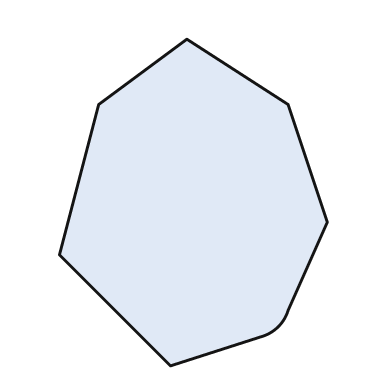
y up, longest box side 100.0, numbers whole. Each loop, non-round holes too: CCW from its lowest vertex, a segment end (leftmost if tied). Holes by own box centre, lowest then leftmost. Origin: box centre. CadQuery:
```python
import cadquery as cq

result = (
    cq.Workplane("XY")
    .moveTo(-7.0, -50.0)
    .lineTo(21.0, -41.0)
    .threePointArc((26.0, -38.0), (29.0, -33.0))
    .lineTo(41.0, -6.0)
    .lineTo(29.0, 30.0)
    .lineTo(-2.0, 50.0)
    .lineTo(-29.0, 30.0)
    .lineTo(-41.0, -16.0)
    .close()
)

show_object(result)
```